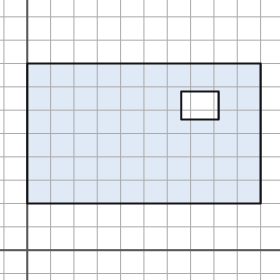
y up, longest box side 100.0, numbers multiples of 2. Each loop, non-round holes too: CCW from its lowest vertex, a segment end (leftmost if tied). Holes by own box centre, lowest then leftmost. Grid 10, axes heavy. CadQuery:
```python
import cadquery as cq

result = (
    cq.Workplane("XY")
    .moveTo(0.0, 20.0)
    .lineTo(100.0, 20.0)
    .lineTo(100.0, 80.0)
    .lineTo(0.0, 80.0)
    .close()
    .moveTo(66.0, 56.0)
    .lineTo(82.0, 56.0)
    .lineTo(82.0, 68.0)
    .lineTo(66.0, 68.0)
    .close()
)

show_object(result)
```